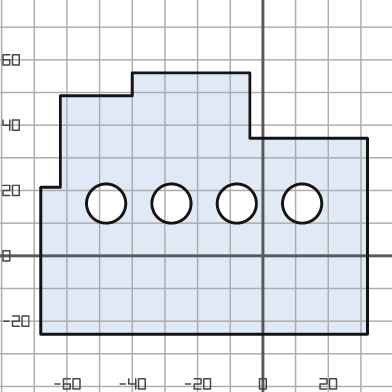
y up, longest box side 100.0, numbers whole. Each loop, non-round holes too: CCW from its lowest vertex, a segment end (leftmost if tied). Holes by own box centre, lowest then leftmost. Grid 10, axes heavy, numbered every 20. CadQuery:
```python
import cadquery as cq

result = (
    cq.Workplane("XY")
    .moveTo(-68.0, -24.0)
    .lineTo(32.0, -24.0)
    .lineTo(32.0, 36.0)
    .lineTo(-4.0, 36.0)
    .lineTo(-4.0, 56.0)
    .lineTo(-40.0, 56.0)
    .lineTo(-40.0, 49.0)
    .lineTo(-62.0, 49.0)
    .lineTo(-62.0, 21.0)
    .lineTo(-68.0, 21.0)
    .close()
    .moveTo(-48.0, 16.0)
    .circle(6.0)
    .moveTo(-28.0, 16.0)
    .circle(6.0)
    .moveTo(-8.0, 16.0)
    .circle(6.0)
    .moveTo(12.0, 16.0)
    .circle(6.0)
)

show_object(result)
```